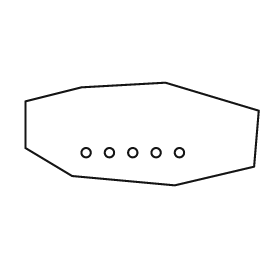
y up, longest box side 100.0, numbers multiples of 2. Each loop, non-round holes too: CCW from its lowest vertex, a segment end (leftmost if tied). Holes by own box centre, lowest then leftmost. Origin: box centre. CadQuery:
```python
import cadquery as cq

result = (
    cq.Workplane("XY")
    .moveTo(14.0, -22.0)
    .lineTo(48.0, -14.0)
    .lineTo(50.0, 10.0)
    .lineTo(10.0, 22.0)
    .lineTo(-26.0, 20.0)
    .lineTo(-50.0, 14.0)
    .lineTo(-50.0, -6.0)
    .lineTo(-30.0, -18.0)
    .close()
    .moveTo(-24.0, -8.0)
    .circle(2.0)
    .moveTo(-14.0, -8.0)
    .circle(2.0)
    .moveTo(-4.0, -8.0)
    .circle(2.0)
    .moveTo(6.0, -8.0)
    .circle(2.0)
    .moveTo(16.0, -8.0)
    .circle(2.0)
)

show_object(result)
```